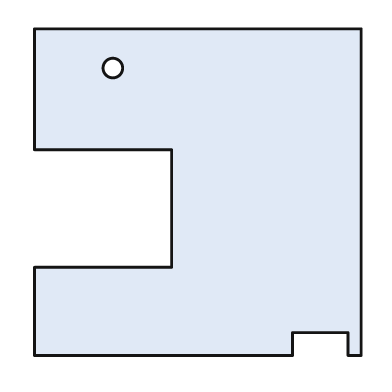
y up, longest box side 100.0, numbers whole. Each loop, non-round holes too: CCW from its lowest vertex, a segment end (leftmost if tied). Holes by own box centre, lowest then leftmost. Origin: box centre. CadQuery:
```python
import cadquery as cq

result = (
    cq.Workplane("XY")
    .moveTo(-50.0, -50.0)
    .lineTo(29.0, -50.0)
    .lineTo(29.0, -43.0)
    .lineTo(46.0, -43.0)
    .lineTo(46.0, -50.0)
    .lineTo(50.0, -50.0)
    .lineTo(50.0, 50.0)
    .lineTo(-50.0, 50.0)
    .lineTo(-50.0, 13.0)
    .lineTo(-8.0, 13.0)
    .lineTo(-8.0, -23.0)
    .lineTo(-50.0, -23.0)
    .close()
    .moveTo(-26.0, 38.0)
    .circle(3.0)
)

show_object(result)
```